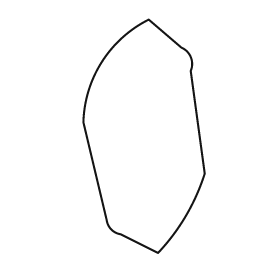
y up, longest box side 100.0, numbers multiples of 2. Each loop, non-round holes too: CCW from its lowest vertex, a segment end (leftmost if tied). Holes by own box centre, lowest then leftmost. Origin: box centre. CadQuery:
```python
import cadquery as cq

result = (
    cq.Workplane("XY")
    .moveTo(6.0, -50.0)
    .threePointArc((18.0, -34.0), (26.0, -16.0))
    .lineTo(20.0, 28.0)
    .threePointArc((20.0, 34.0), (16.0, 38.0))
    .lineTo(2.0, 50.0)
    .threePointArc((-18.0, 32.0), (-26.0, 6.0))
    .lineTo(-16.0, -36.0)
    .threePointArc((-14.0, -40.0), (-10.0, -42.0))
    .close()
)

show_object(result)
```